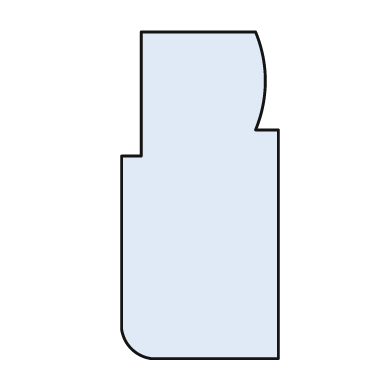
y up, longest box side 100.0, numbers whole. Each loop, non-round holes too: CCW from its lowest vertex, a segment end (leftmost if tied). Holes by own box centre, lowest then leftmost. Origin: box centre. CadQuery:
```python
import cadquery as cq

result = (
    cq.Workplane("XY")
    .moveTo(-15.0, -50.0)
    .lineTo(24.0, -50.0)
    .lineTo(24.0, 20.0)
    .lineTo(17.0, 20.0)
    .threePointArc((20.0, 35.0), (17.0, 50.0))
    .lineTo(-18.0, 50.0)
    .lineTo(-18.0, 12.0)
    .lineTo(-24.0, 12.0)
    .lineTo(-24.0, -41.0)
    .threePointArc((-21.0, -47.0), (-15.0, -50.0))
    .close()
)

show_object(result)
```